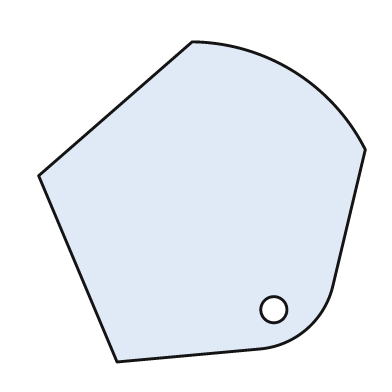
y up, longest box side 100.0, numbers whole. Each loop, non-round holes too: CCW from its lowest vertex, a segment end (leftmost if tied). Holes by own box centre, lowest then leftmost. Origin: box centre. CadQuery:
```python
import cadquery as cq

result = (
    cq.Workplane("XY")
    .moveTo(-26.0, -49.0)
    .lineTo(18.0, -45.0)
    .threePointArc((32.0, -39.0), (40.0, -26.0))
    .lineTo(50.0, 16.0)
    .threePointArc((28.0, 40.0), (-3.0, 49.0))
    .lineTo(-50.0, 8.0)
    .close()
    .moveTo(22.0, -33.0)
    .circle(4.0)
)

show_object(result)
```